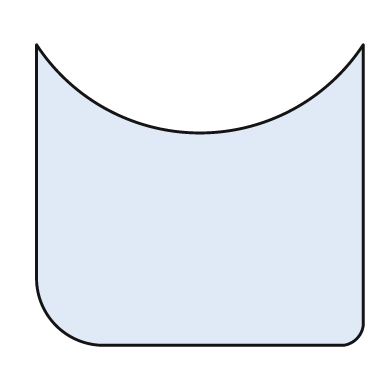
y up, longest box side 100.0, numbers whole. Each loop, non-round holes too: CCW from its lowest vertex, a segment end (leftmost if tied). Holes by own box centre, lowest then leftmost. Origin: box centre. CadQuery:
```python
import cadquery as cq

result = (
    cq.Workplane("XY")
    .moveTo(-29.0, -46.0)
    .lineTo(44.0, -46.0)
    .threePointArc((48.0, -44.0), (50.0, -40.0))
    .lineTo(50.0, 46.0)
    .threePointArc((0.0, 19.0), (-50.0, 46.0))
    .lineTo(-50.0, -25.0)
    .threePointArc((-44.0, -40.0), (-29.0, -46.0))
    .close()
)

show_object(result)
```